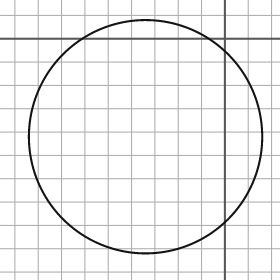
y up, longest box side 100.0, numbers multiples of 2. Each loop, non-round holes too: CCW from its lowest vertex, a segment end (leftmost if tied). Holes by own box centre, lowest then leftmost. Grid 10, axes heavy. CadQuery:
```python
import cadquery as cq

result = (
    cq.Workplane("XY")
    .moveTo(-34.0, -42.0)
    .circle(50.0)
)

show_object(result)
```